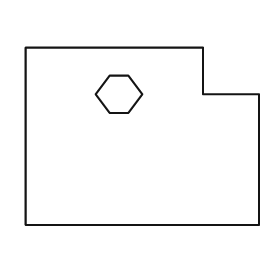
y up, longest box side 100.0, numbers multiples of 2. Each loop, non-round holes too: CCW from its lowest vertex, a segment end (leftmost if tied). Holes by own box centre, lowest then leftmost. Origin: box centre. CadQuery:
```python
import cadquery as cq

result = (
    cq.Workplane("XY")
    .moveTo(-50.0, -38.0)
    .lineTo(50.0, -38.0)
    .lineTo(50.0, 18.0)
    .lineTo(26.0, 18.0)
    .lineTo(26.0, 38.0)
    .lineTo(-50.0, 38.0)
    .close()
    .moveTo(-14.0, 10.0)
    .lineTo(-6.0, 10.0)
    .lineTo(0.0, 18.0)
    .lineTo(-6.0, 26.0)
    .lineTo(-14.0, 26.0)
    .lineTo(-20.0, 18.0)
    .close()
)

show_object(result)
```